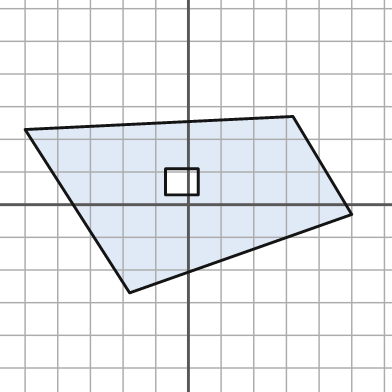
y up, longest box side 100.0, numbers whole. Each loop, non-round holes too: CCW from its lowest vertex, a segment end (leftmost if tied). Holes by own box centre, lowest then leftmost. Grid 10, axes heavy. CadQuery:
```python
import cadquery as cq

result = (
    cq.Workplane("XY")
    .moveTo(-18.0, -27.0)
    .lineTo(50.0, -3.0)
    .lineTo(32.0, 27.0)
    .lineTo(-50.0, 23.0)
    .close()
    .moveTo(-7.0, 3.0)
    .lineTo(3.0, 3.0)
    .lineTo(3.0, 11.0)
    .lineTo(-7.0, 11.0)
    .close()
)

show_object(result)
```